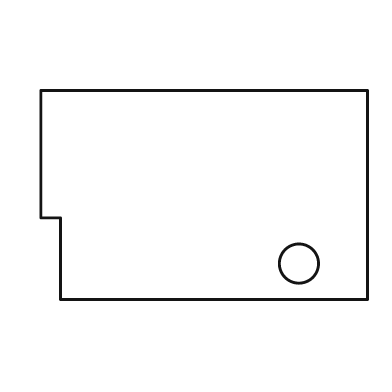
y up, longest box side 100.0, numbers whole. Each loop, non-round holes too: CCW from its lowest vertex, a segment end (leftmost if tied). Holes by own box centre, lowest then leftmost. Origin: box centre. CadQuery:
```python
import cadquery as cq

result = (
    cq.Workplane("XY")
    .moveTo(-44.0, -32.0)
    .lineTo(50.0, -32.0)
    .lineTo(50.0, 32.0)
    .lineTo(-50.0, 32.0)
    .lineTo(-50.0, -7.0)
    .lineTo(-44.0, -7.0)
    .close()
    .moveTo(29.0, -21.0)
    .circle(6.0)
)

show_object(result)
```